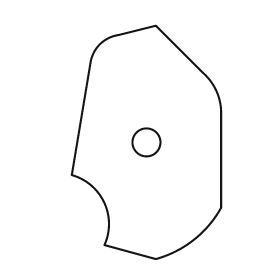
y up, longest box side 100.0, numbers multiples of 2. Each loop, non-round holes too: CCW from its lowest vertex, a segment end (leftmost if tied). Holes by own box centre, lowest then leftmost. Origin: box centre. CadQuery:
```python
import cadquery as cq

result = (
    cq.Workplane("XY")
    .moveTo(4.0, -50.0)
    .threePointArc((20.0, -42.0), (32.0, -28.0))
    .lineTo(32.0, 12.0)
    .threePointArc((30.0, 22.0), (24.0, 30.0))
    .lineTo(4.0, 50.0)
    .lineTo(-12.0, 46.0)
    .threePointArc((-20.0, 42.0), (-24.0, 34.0))
    .lineTo(-32.0, -14.0)
    .threePointArc((-18.0, -26.0), (-18.0, -44.0))
    .close()
    .moveTo(0.0, 0.0)
    .circle(6.0)
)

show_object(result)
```